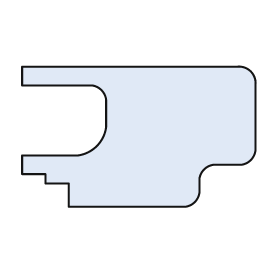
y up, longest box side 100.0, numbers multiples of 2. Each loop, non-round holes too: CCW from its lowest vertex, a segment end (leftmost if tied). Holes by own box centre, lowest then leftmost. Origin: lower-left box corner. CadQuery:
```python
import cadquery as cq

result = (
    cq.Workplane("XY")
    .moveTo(20.0, 0.0)
    .lineTo(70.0, 0.0)
    .threePointArc((74.0, 2.0), (76.0, 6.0))
    .lineTo(76.0, 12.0)
    .threePointArc((78.0, 16.0), (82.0, 18.0))
    .lineTo(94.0, 18.0)
    .threePointArc((98.0, 20.0), (100.0, 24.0))
    .lineTo(100.0, 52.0)
    .threePointArc((98.0, 58.0), (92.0, 60.0))
    .lineTo(0.0, 60.0)
    .lineTo(0.0, 52.0)
    .lineTo(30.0, 52.0)
    .threePointArc((34.0, 50.0), (36.0, 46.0))
    .lineTo(36.0, 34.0)
    .threePointArc((32.0, 26.0), (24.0, 22.0))
    .lineTo(0.0, 22.0)
    .lineTo(0.0, 14.0)
    .lineTo(10.0, 14.0)
    .lineTo(10.0, 10.0)
    .lineTo(20.0, 10.0)
    .close()
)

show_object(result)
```